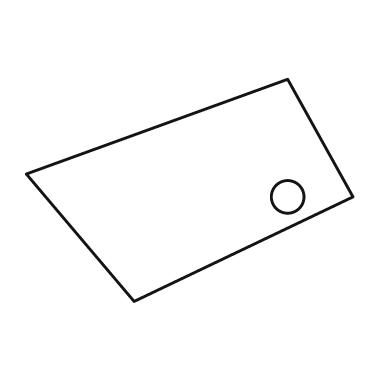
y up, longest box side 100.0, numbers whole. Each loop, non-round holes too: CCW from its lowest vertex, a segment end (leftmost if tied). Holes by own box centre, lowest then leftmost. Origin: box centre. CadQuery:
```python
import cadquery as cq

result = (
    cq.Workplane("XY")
    .moveTo(-17.0, -34.0)
    .lineTo(50.0, -2.0)
    .lineTo(30.0, 34.0)
    .lineTo(-50.0, 5.0)
    .close()
    .moveTo(30.0, -2.0)
    .circle(5.0)
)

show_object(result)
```